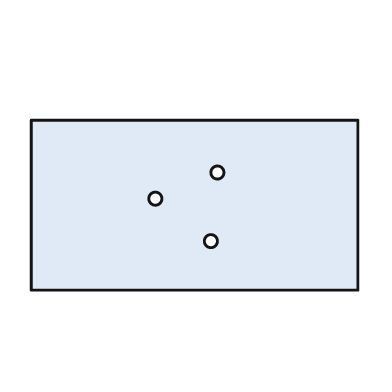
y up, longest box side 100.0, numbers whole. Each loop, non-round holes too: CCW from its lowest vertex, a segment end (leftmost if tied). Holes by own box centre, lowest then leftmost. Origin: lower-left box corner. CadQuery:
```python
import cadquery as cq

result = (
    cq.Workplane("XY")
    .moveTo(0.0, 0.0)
    .lineTo(100.0, 0.0)
    .lineTo(100.0, 52.0)
    .lineTo(0.0, 52.0)
    .close()
    .moveTo(55.0, 15.0)
    .circle(2.0)
    .moveTo(38.0, 28.0)
    .circle(2.0)
    .moveTo(57.0, 36.0)
    .circle(2.0)
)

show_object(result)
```